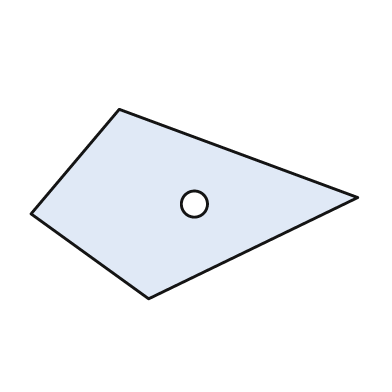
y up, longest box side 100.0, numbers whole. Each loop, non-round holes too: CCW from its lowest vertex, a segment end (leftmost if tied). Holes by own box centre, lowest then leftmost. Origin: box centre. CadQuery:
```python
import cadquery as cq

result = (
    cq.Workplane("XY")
    .moveTo(-14.0, -29.0)
    .lineTo(50.0, 2.0)
    .lineTo(-23.0, 29.0)
    .lineTo(-50.0, -3.0)
    .close()
    .moveTo(0.0, 0.0)
    .circle(4.0)
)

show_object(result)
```